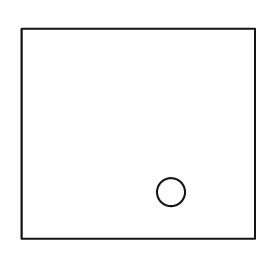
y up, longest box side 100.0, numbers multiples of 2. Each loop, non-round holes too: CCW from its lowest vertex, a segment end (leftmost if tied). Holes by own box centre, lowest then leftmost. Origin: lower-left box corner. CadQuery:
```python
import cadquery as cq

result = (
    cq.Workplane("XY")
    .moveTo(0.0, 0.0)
    .lineTo(100.0, 0.0)
    .lineTo(100.0, 90.0)
    .lineTo(0.0, 90.0)
    .close()
    .moveTo(64.0, 20.0)
    .circle(6.0)
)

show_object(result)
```